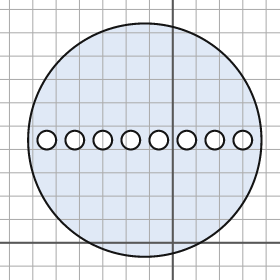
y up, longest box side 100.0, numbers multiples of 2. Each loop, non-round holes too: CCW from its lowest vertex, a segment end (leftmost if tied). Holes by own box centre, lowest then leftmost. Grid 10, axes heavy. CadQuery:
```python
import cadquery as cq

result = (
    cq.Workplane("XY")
    .moveTo(-12.0, 44.0)
    .circle(50.0)
    .moveTo(-54.0, 44.0)
    .circle(4.0)
    .moveTo(-42.0, 44.0)
    .circle(4.0)
    .moveTo(-30.0, 44.0)
    .circle(4.0)
    .moveTo(-18.0, 44.0)
    .circle(4.0)
    .moveTo(-6.0, 44.0)
    .circle(4.0)
    .moveTo(6.0, 44.0)
    .circle(4.0)
    .moveTo(18.0, 44.0)
    .circle(4.0)
    .moveTo(30.0, 44.0)
    .circle(4.0)
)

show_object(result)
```